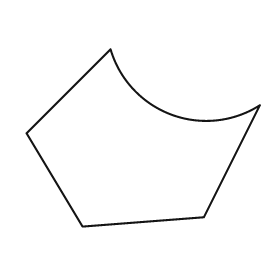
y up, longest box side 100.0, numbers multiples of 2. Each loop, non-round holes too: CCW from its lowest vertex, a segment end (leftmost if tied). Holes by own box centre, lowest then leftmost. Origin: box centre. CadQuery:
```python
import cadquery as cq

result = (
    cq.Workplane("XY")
    .moveTo(-26.0, -38.0)
    .lineTo(26.0, -34.0)
    .lineTo(50.0, 14.0)
    .threePointArc((12.0, 10.0), (-14.0, 38.0))
    .lineTo(-50.0, 2.0)
    .close()
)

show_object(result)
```